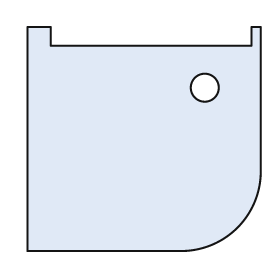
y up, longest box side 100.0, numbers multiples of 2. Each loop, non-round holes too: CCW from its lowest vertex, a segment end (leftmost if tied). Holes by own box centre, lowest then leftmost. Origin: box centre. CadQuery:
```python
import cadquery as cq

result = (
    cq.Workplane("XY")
    .moveTo(-50.0, -48.0)
    .lineTo(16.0, -48.0)
    .threePointArc((40.0, -38.0), (50.0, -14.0))
    .lineTo(50.0, 48.0)
    .lineTo(46.0, 48.0)
    .lineTo(46.0, 40.0)
    .lineTo(-40.0, 40.0)
    .lineTo(-40.0, 48.0)
    .lineTo(-50.0, 48.0)
    .close()
    .moveTo(26.0, 22.0)
    .circle(6.0)
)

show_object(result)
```